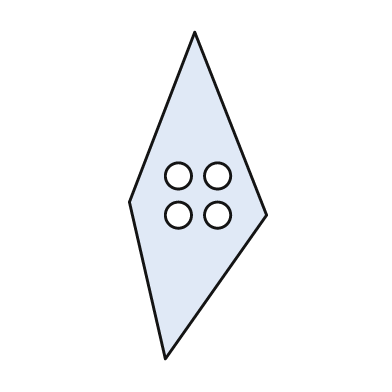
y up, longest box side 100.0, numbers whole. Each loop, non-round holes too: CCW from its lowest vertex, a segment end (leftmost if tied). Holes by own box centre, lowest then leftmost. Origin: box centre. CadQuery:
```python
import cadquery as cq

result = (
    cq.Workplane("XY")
    .moveTo(-10.0, -50.0)
    .lineTo(21.0, -6.0)
    .lineTo(-1.0, 50.0)
    .lineTo(-21.0, -2.0)
    .close()
    .moveTo(-6.0, -6.0)
    .circle(4.0)
    .moveTo(6.0, -6.0)
    .circle(4.0)
    .moveTo(-6.0, 6.0)
    .circle(4.0)
    .moveTo(6.0, 6.0)
    .circle(4.0)
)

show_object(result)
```